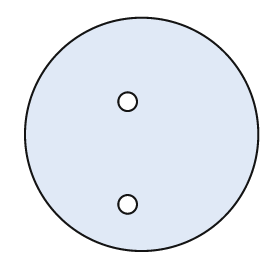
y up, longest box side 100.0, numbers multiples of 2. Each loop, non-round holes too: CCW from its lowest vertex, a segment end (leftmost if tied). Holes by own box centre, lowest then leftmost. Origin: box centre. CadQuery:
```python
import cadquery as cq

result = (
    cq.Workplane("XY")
    .moveTo(0.0, 0.0)
    .circle(50.0)
    .moveTo(-6.0, -30.0)
    .circle(4.0)
    .moveTo(-6.0, 14.0)
    .circle(4.0)
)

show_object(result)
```